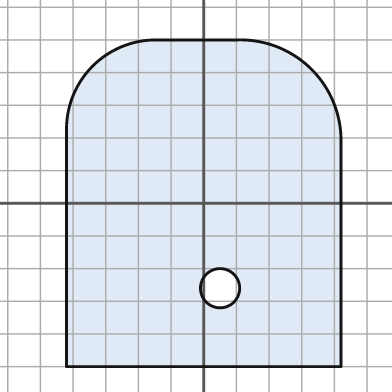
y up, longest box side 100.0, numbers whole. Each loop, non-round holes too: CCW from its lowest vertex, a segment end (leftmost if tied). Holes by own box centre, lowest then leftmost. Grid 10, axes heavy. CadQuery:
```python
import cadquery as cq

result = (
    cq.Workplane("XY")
    .moveTo(-42.0, -50.0)
    .lineTo(42.0, -50.0)
    .lineTo(42.0, 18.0)
    .threePointArc((33.0, 41.0), (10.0, 50.0))
    .lineTo(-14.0, 50.0)
    .threePointArc((-34.0, 42.0), (-42.0, 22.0))
    .close()
    .moveTo(5.0, -26.0)
    .circle(6.0)
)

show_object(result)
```